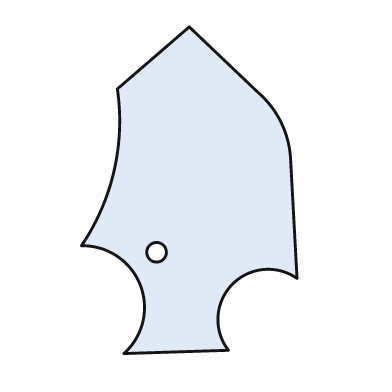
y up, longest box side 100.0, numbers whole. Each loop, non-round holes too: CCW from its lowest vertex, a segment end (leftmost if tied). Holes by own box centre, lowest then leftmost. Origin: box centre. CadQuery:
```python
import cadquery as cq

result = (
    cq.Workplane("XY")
    .moveTo(-20.0, -50.0)
    .lineTo(12.0, -49.0)
    .threePointArc((13.0, -29.0), (33.0, -27.0))
    .lineTo(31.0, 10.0)
    .threePointArc((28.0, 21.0), (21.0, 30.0))
    .lineTo(0.0, 50.0)
    .lineTo(-22.0, 31.0)
    .threePointArc((-23.0, 6.0), (-33.0, -17.0))
    .threePointArc((-15.0, -29.0), (-20.0, -50.0))
    .close()
    .moveTo(-10.0, -19.0)
    .circle(3.0)
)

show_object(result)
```